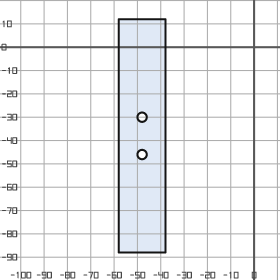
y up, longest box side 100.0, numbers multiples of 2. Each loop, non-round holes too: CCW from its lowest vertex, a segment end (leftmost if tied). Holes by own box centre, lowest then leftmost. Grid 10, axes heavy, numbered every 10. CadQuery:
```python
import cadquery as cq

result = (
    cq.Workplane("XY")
    .moveTo(-58.0, -88.0)
    .lineTo(-38.0, -88.0)
    .lineTo(-38.0, 12.0)
    .lineTo(-58.0, 12.0)
    .close()
    .moveTo(-48.0, -46.0)
    .circle(2.0)
    .moveTo(-48.0, -30.0)
    .circle(2.0)
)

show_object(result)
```